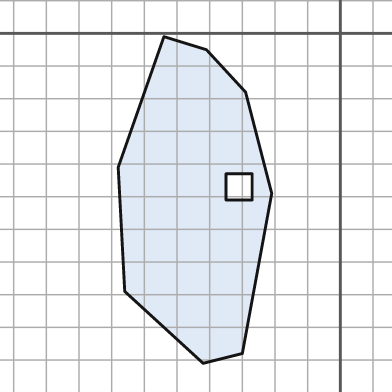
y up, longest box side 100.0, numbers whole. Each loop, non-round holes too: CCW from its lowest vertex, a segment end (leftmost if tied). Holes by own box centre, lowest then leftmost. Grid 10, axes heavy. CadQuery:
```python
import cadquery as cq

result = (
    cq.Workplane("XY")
    .moveTo(-42.0, -101.0)
    .lineTo(-30.0, -98.0)
    .lineTo(-21.0, -49.0)
    .lineTo(-29.0, -18.0)
    .lineTo(-41.0, -5.0)
    .lineTo(-54.0, -1.0)
    .lineTo(-68.0, -41.0)
    .lineTo(-66.0, -79.0)
    .close()
    .moveTo(-35.0, -51.0)
    .lineTo(-27.0, -51.0)
    .lineTo(-27.0, -43.0)
    .lineTo(-35.0, -43.0)
    .close()
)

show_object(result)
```